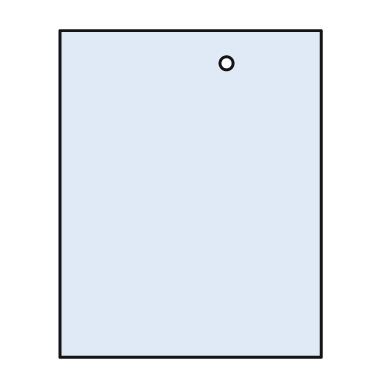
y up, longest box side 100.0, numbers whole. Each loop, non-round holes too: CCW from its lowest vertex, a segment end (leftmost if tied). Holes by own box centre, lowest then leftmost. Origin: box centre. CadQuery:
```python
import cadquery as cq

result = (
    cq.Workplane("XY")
    .moveTo(-40.0, -50.0)
    .lineTo(40.0, -50.0)
    .lineTo(40.0, 50.0)
    .lineTo(-40.0, 50.0)
    .close()
    .moveTo(11.0, 40.0)
    .circle(2.0)
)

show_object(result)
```